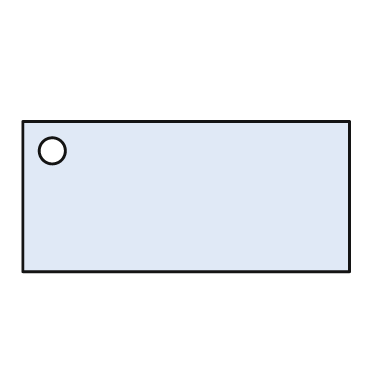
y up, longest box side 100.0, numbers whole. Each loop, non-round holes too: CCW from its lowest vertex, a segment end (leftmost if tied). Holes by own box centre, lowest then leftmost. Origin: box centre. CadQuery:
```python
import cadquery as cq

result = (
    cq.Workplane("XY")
    .moveTo(-50.0, -23.0)
    .lineTo(50.0, -23.0)
    .lineTo(50.0, 23.0)
    .lineTo(-50.0, 23.0)
    .close()
    .moveTo(-41.0, 14.0)
    .circle(4.0)
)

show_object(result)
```